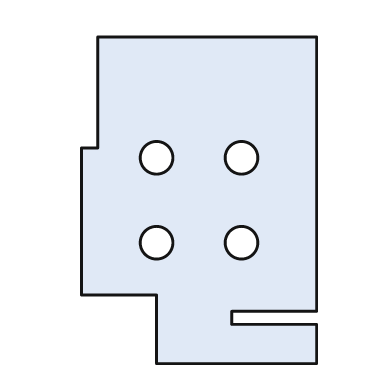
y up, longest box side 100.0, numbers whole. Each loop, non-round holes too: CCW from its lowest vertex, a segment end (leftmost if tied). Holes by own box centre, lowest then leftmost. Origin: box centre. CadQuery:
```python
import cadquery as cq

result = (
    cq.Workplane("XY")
    .moveTo(-13.0, -50.0)
    .lineTo(36.0, -50.0)
    .lineTo(36.0, -38.0)
    .lineTo(10.0, -38.0)
    .lineTo(10.0, -34.0)
    .lineTo(36.0, -34.0)
    .lineTo(36.0, 50.0)
    .lineTo(-31.0, 50.0)
    .lineTo(-31.0, 16.0)
    .lineTo(-36.0, 16.0)
    .lineTo(-36.0, -29.0)
    .lineTo(-13.0, -29.0)
    .close()
    .moveTo(-13.0, -13.0)
    .circle(5.0)
    .moveTo(13.0, -13.0)
    .circle(5.0)
    .moveTo(-13.0, 13.0)
    .circle(5.0)
    .moveTo(13.0, 13.0)
    .circle(5.0)
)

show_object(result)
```